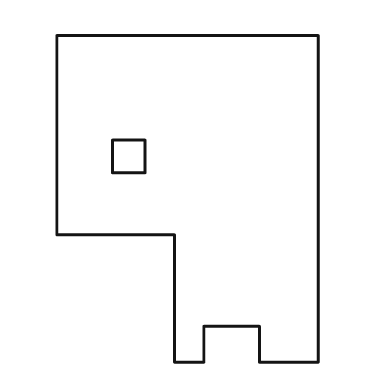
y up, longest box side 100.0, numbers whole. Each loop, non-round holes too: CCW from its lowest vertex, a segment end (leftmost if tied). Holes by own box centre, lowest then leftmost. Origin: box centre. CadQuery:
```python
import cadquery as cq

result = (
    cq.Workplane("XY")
    .moveTo(-4.0, -50.0)
    .lineTo(5.0, -50.0)
    .lineTo(5.0, -39.0)
    .lineTo(22.0, -39.0)
    .lineTo(22.0, -50.0)
    .lineTo(40.0, -50.0)
    .lineTo(40.0, 50.0)
    .lineTo(-40.0, 50.0)
    .lineTo(-40.0, -11.0)
    .lineTo(-4.0, -11.0)
    .close()
    .moveTo(-23.0, 8.0)
    .lineTo(-13.0, 8.0)
    .lineTo(-13.0, 18.0)
    .lineTo(-23.0, 18.0)
    .close()
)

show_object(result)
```